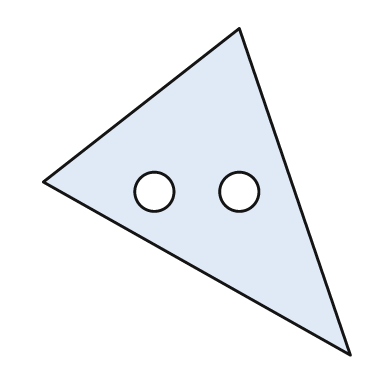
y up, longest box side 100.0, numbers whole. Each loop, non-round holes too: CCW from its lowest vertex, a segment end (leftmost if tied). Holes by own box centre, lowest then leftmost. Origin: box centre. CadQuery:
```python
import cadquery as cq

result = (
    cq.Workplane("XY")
    .moveTo(47.0, -50.0)
    .lineTo(13.0, 50.0)
    .lineTo(-47.0, 3.0)
    .close()
    .moveTo(-13.0, 0.0)
    .circle(6.0)
    .moveTo(13.0, 0.0)
    .circle(6.0)
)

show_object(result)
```